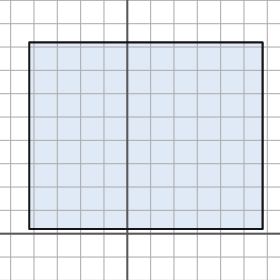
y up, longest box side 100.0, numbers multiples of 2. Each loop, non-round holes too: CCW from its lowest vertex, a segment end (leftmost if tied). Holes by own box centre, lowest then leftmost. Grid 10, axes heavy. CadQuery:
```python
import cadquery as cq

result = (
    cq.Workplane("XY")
    .moveTo(-42.0, 2.0)
    .lineTo(58.0, 2.0)
    .lineTo(58.0, 82.0)
    .lineTo(-42.0, 82.0)
    .close()
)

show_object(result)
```